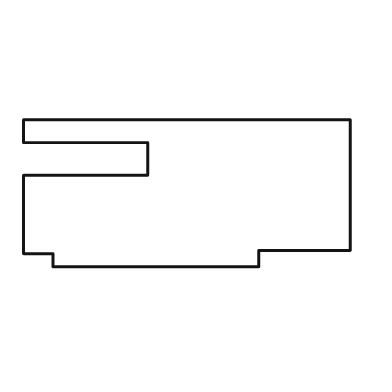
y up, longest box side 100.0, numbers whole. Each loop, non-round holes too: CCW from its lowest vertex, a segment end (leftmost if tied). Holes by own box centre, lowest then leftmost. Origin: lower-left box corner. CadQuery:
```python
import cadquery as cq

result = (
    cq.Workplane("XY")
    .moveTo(9.0, 0.0)
    .lineTo(72.0, 0.0)
    .lineTo(72.0, 5.0)
    .lineTo(100.0, 5.0)
    .lineTo(100.0, 45.0)
    .lineTo(0.0, 45.0)
    .lineTo(0.0, 38.0)
    .lineTo(38.0, 38.0)
    .lineTo(38.0, 28.0)
    .lineTo(0.0, 28.0)
    .lineTo(0.0, 4.0)
    .lineTo(9.0, 4.0)
    .close()
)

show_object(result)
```